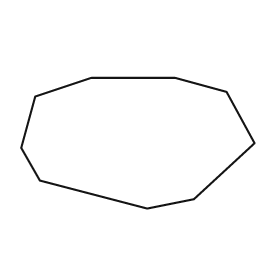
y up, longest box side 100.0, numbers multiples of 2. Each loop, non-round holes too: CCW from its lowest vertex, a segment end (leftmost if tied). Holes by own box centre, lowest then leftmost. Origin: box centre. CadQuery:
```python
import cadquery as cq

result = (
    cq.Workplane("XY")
    .moveTo(4.0, -28.0)
    .lineTo(24.0, -24.0)
    .lineTo(50.0, 0.0)
    .lineTo(38.0, 22.0)
    .lineTo(16.0, 28.0)
    .lineTo(-20.0, 28.0)
    .lineTo(-44.0, 20.0)
    .lineTo(-50.0, -2.0)
    .lineTo(-42.0, -16.0)
    .close()
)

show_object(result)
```